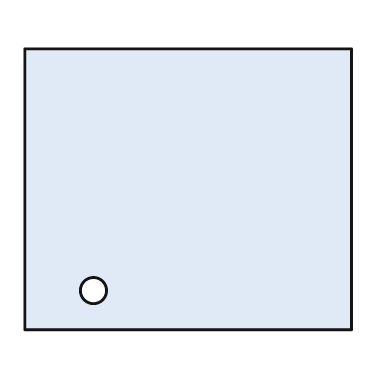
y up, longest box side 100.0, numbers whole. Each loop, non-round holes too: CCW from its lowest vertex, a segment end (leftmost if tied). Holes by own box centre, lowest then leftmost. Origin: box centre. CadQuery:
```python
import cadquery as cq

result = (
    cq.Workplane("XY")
    .moveTo(-50.0, -43.0)
    .lineTo(50.0, -43.0)
    .lineTo(50.0, 43.0)
    .lineTo(-50.0, 43.0)
    .close()
    .moveTo(-29.0, -31.0)
    .circle(4.0)
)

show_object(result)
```